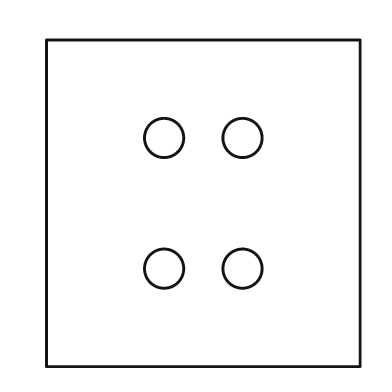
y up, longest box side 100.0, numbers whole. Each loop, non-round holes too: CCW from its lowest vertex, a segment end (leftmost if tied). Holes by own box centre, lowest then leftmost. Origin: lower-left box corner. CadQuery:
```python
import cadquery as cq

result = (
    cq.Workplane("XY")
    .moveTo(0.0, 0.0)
    .lineTo(96.0, 0.0)
    .lineTo(96.0, 100.0)
    .lineTo(0.0, 100.0)
    .close()
    .moveTo(36.0, 30.0)
    .circle(6.0)
    .moveTo(60.0, 30.0)
    .circle(6.0)
    .moveTo(36.0, 70.0)
    .circle(6.0)
    .moveTo(60.0, 70.0)
    .circle(6.0)
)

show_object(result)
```